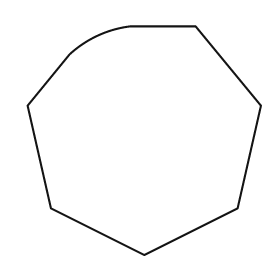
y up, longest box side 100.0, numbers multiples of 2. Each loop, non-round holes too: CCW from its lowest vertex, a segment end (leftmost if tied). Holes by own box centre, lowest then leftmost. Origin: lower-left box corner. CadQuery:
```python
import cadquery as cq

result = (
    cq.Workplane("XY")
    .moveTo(50.0, 0.0)
    .lineTo(90.0, 20.0)
    .lineTo(100.0, 64.0)
    .lineTo(72.0, 98.0)
    .lineTo(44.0, 98.0)
    .threePointArc((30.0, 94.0), (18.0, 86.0))
    .lineTo(0.0, 64.0)
    .lineTo(10.0, 20.0)
    .close()
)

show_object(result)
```